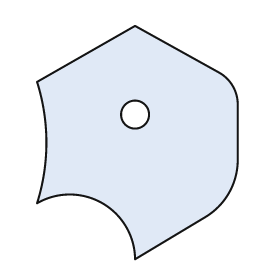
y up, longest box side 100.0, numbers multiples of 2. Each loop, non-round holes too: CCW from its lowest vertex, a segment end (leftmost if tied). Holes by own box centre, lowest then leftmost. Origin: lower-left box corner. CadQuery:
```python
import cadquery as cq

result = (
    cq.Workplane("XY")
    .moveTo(42.0, 0.0)
    .lineTo(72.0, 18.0)
    .threePointArc((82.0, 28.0), (86.0, 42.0))
    .lineTo(86.0, 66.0)
    .threePointArc((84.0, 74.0), (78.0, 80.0))
    .lineTo(42.0, 100.0)
    .lineTo(0.0, 76.0)
    .threePointArc((4.0, 50.0), (0.0, 24.0))
    .threePointArc((28.0, 24.0), (42.0, 0.0))
    .close()
    .moveTo(42.0, 62.0)
    .circle(6.0)
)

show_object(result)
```